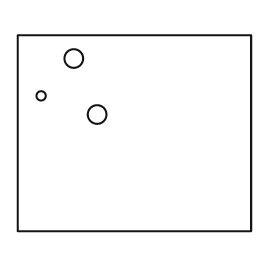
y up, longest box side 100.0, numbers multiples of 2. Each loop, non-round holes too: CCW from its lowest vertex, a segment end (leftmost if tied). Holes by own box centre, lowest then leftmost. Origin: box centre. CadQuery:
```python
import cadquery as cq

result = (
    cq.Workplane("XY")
    .moveTo(-50.0, -42.0)
    .lineTo(50.0, -42.0)
    .lineTo(50.0, 42.0)
    .lineTo(-50.0, 42.0)
    .close()
    .moveTo(-16.0, 8.0)
    .circle(4.0)
    .moveTo(-40.0, 16.0)
    .circle(2.0)
    .moveTo(-26.0, 32.0)
    .circle(4.0)
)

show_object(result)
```